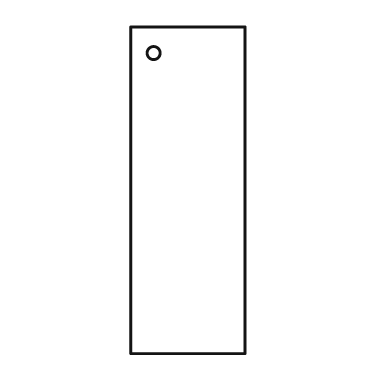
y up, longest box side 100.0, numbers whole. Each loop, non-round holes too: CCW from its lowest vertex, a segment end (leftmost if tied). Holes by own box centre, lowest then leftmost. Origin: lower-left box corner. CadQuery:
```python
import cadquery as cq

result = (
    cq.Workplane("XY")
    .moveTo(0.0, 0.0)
    .lineTo(35.0, 0.0)
    .lineTo(35.0, 100.0)
    .lineTo(0.0, 100.0)
    .close()
    .moveTo(7.0, 92.0)
    .circle(2.0)
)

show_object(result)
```